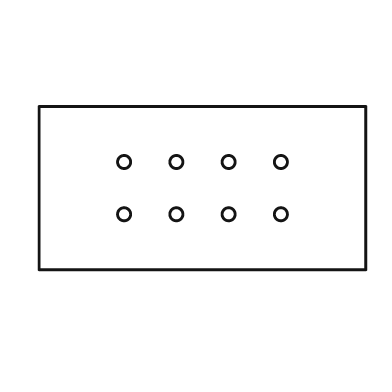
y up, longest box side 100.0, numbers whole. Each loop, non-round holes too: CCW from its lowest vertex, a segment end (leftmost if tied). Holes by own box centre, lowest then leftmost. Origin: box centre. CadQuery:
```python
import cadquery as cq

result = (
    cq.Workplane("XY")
    .moveTo(-50.0, -25.0)
    .lineTo(50.0, -25.0)
    .lineTo(50.0, 25.0)
    .lineTo(-50.0, 25.0)
    .close()
    .moveTo(-24.0, -8.0)
    .circle(2.0)
    .moveTo(-8.0, -8.0)
    .circle(2.0)
    .moveTo(8.0, -8.0)
    .circle(2.0)
    .moveTo(24.0, -8.0)
    .circle(2.0)
    .moveTo(-24.0, 8.0)
    .circle(2.0)
    .moveTo(-8.0, 8.0)
    .circle(2.0)
    .moveTo(8.0, 8.0)
    .circle(2.0)
    .moveTo(24.0, 8.0)
    .circle(2.0)
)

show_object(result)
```